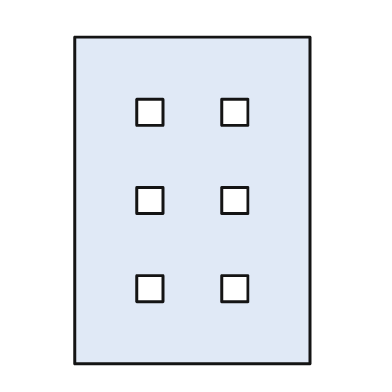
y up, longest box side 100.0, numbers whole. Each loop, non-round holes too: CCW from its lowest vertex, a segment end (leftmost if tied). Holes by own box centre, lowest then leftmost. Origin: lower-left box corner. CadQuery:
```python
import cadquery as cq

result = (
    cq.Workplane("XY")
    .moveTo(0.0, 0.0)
    .lineTo(72.0, 0.0)
    .lineTo(72.0, 100.0)
    .lineTo(0.0, 100.0)
    .close()
    .moveTo(19.0, 19.0)
    .lineTo(27.0, 19.0)
    .lineTo(27.0, 27.0)
    .lineTo(19.0, 27.0)
    .close()
    .moveTo(45.0, 19.0)
    .lineTo(53.0, 19.0)
    .lineTo(53.0, 27.0)
    .lineTo(45.0, 27.0)
    .close()
    .moveTo(19.0, 46.0)
    .lineTo(27.0, 46.0)
    .lineTo(27.0, 54.0)
    .lineTo(19.0, 54.0)
    .close()
    .moveTo(45.0, 46.0)
    .lineTo(53.0, 46.0)
    .lineTo(53.0, 54.0)
    .lineTo(45.0, 54.0)
    .close()
    .moveTo(19.0, 73.0)
    .lineTo(27.0, 73.0)
    .lineTo(27.0, 81.0)
    .lineTo(19.0, 81.0)
    .close()
    .moveTo(45.0, 73.0)
    .lineTo(53.0, 73.0)
    .lineTo(53.0, 81.0)
    .lineTo(45.0, 81.0)
    .close()
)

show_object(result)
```